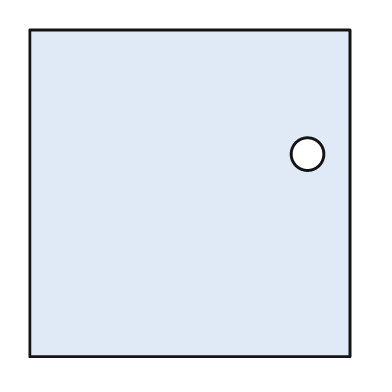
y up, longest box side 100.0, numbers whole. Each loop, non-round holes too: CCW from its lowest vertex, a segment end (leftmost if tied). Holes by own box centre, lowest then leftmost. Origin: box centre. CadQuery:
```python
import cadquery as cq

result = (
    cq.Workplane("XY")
    .moveTo(-49.0, -50.0)
    .lineTo(49.0, -50.0)
    .lineTo(49.0, 50.0)
    .lineTo(-49.0, 50.0)
    .close()
    .moveTo(36.0, 12.0)
    .circle(5.0)
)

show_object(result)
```